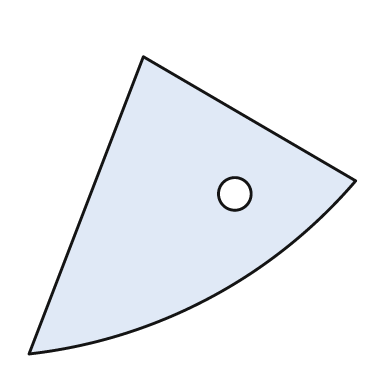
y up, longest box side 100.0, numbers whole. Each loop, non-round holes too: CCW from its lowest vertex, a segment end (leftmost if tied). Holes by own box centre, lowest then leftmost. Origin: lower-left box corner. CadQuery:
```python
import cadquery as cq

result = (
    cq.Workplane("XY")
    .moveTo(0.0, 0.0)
    .threePointArc((55.0, 17.0), (100.0, 53.0))
    .lineTo(35.0, 91.0)
    .close()
    .moveTo(63.0, 49.0)
    .circle(5.0)
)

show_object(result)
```